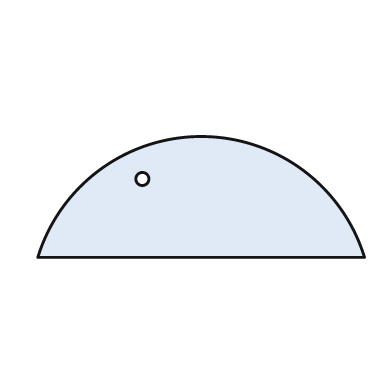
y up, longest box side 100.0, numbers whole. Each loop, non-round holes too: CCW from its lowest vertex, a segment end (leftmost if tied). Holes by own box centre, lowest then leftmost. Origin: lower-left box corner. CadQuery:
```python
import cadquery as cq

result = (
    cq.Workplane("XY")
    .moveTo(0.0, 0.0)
    .lineTo(100.0, 0.0)
    .threePointArc((50.0, 37.0), (0.0, 0.0))
    .close()
    .moveTo(32.0, 24.0)
    .circle(2.0)
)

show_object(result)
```